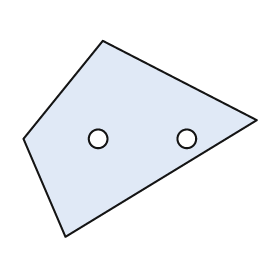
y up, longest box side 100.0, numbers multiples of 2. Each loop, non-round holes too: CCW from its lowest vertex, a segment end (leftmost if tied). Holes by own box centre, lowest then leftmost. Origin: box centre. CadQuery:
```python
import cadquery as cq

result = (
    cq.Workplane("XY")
    .moveTo(-32.0, -42.0)
    .lineTo(50.0, 8.0)
    .lineTo(-16.0, 42.0)
    .lineTo(-50.0, 0.0)
    .close()
    .moveTo(-18.0, 0.0)
    .circle(4.0)
    .moveTo(20.0, 0.0)
    .circle(4.0)
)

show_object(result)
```